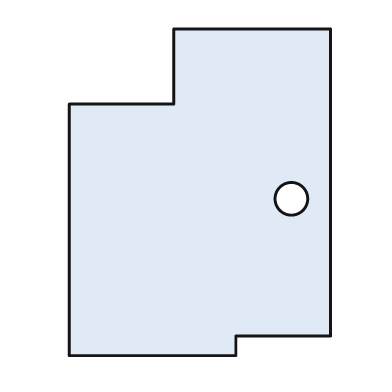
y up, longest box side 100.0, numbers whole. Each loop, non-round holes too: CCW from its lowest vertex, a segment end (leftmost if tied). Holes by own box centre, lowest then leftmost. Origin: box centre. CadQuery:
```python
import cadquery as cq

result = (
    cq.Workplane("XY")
    .moveTo(-40.0, -50.0)
    .lineTo(11.0, -50.0)
    .lineTo(11.0, -44.0)
    .lineTo(40.0, -44.0)
    .lineTo(40.0, 50.0)
    .lineTo(-8.0, 50.0)
    .lineTo(-8.0, 27.0)
    .lineTo(-40.0, 27.0)
    .close()
    .moveTo(28.0, -2.0)
    .circle(5.0)
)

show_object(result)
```